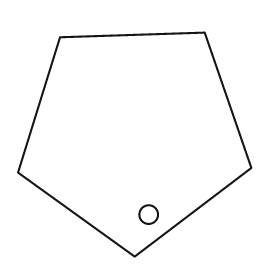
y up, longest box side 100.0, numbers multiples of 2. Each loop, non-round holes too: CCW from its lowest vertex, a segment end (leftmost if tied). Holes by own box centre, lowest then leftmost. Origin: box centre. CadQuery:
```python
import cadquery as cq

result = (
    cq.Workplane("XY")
    .moveTo(0.0, -48.0)
    .lineTo(50.0, -10.0)
    .lineTo(30.0, 48.0)
    .lineTo(-32.0, 46.0)
    .lineTo(-50.0, -12.0)
    .close()
    .moveTo(6.0, -30.0)
    .circle(4.0)
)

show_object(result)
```